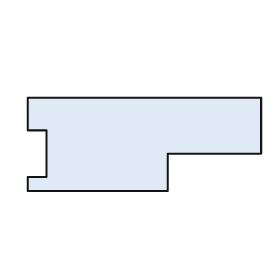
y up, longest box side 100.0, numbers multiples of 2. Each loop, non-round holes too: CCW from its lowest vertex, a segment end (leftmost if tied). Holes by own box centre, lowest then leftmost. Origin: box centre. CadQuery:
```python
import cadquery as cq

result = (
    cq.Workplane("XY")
    .moveTo(-50.0, -20.0)
    .lineTo(10.0, -20.0)
    .lineTo(10.0, -4.0)
    .lineTo(50.0, -4.0)
    .lineTo(50.0, 20.0)
    .lineTo(-50.0, 20.0)
    .lineTo(-50.0, 6.0)
    .lineTo(-42.0, 6.0)
    .lineTo(-42.0, -14.0)
    .lineTo(-50.0, -14.0)
    .close()
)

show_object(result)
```